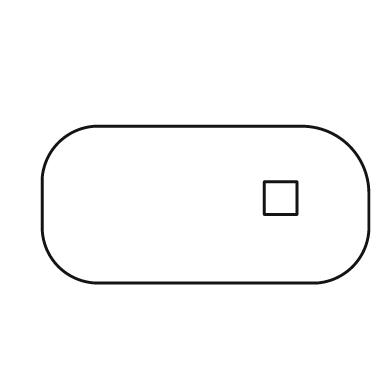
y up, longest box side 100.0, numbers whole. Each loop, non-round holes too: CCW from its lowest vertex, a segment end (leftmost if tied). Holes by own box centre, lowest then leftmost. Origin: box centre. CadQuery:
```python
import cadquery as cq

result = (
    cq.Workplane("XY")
    .moveTo(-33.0, -24.0)
    .lineTo(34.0, -24.0)
    .threePointArc((45.0, -19.0), (50.0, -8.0))
    .lineTo(50.0, 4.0)
    .threePointArc((44.0, 18.0), (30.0, 24.0))
    .lineTo(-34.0, 24.0)
    .threePointArc((-45.0, 19.0), (-50.0, 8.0))
    .lineTo(-50.0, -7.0)
    .threePointArc((-45.0, -19.0), (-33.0, -24.0))
    .close()
    .moveTo(18.0, -3.0)
    .lineTo(28.0, -3.0)
    .lineTo(28.0, 7.0)
    .lineTo(18.0, 7.0)
    .close()
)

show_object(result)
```